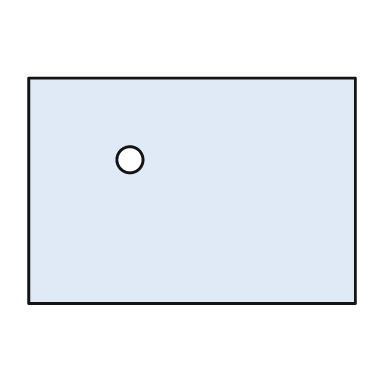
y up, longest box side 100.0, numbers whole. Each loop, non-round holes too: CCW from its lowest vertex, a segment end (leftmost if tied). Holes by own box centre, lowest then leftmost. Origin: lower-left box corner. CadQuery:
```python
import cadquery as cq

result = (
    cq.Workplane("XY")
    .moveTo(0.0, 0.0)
    .lineTo(100.0, 0.0)
    .lineTo(100.0, 69.0)
    .lineTo(0.0, 69.0)
    .close()
    .moveTo(31.0, 44.0)
    .circle(4.0)
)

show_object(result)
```